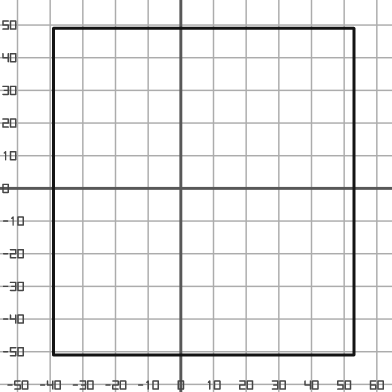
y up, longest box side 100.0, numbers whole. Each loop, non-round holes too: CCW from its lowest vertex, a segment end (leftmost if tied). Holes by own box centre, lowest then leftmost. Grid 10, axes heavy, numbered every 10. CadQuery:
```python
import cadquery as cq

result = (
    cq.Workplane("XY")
    .moveTo(-39.0, -51.0)
    .lineTo(53.0, -51.0)
    .lineTo(53.0, 49.0)
    .lineTo(-39.0, 49.0)
    .close()
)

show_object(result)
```